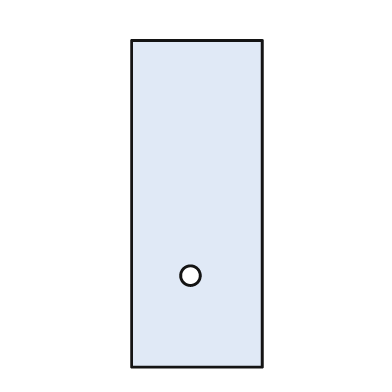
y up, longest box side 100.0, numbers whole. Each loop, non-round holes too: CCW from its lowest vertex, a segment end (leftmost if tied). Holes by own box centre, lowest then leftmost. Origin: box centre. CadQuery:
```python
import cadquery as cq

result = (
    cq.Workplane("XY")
    .moveTo(-20.0, -50.0)
    .lineTo(20.0, -50.0)
    .lineTo(20.0, 50.0)
    .lineTo(-20.0, 50.0)
    .close()
    .moveTo(-2.0, -22.0)
    .circle(3.0)
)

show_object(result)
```